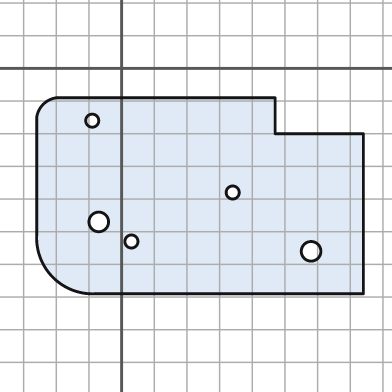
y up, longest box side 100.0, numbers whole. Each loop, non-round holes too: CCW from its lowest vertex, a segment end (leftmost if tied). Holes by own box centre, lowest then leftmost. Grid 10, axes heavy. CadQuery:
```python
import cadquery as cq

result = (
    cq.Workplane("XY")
    .moveTo(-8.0, -69.0)
    .lineTo(74.0, -69.0)
    .lineTo(74.0, -20.0)
    .lineTo(47.0, -20.0)
    .lineTo(47.0, -9.0)
    .lineTo(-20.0, -9.0)
    .threePointArc((-24.0, -11.0), (-26.0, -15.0))
    .lineTo(-26.0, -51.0)
    .threePointArc((-21.0, -64.0), (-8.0, -69.0))
    .close()
    .moveTo(58.0, -56.0)
    .circle(3.0)
    .moveTo(3.0, -53.0)
    .circle(2.0)
    .moveTo(-7.0, -47.0)
    .circle(3.0)
    .moveTo(34.0, -38.0)
    .circle(2.0)
    .moveTo(-9.0, -16.0)
    .circle(2.0)
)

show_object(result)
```